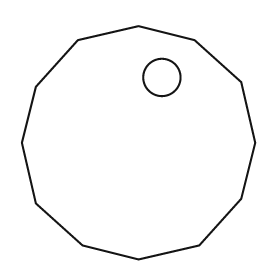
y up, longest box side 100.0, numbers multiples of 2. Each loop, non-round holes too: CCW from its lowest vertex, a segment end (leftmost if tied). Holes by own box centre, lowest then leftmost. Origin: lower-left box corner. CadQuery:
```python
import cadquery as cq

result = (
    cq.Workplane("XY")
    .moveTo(50.0, 0.0)
    .lineTo(76.0, 6.0)
    .lineTo(94.0, 26.0)
    .lineTo(100.0, 50.0)
    .lineTo(94.0, 76.0)
    .lineTo(74.0, 94.0)
    .lineTo(50.0, 100.0)
    .lineTo(24.0, 94.0)
    .lineTo(6.0, 74.0)
    .lineTo(0.0, 50.0)
    .lineTo(6.0, 24.0)
    .lineTo(26.0, 6.0)
    .close()
    .moveTo(60.0, 78.0)
    .circle(8.0)
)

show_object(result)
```